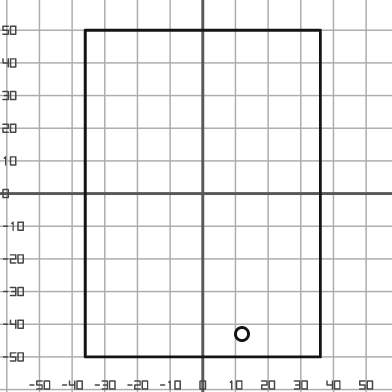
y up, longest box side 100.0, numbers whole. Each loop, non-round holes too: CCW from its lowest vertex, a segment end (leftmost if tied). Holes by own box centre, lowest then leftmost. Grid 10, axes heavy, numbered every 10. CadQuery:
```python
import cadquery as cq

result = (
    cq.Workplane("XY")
    .moveTo(-36.0, -50.0)
    .lineTo(36.0, -50.0)
    .lineTo(36.0, 50.0)
    .lineTo(-36.0, 50.0)
    .close()
    .moveTo(12.0, -43.0)
    .circle(2.0)
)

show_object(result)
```